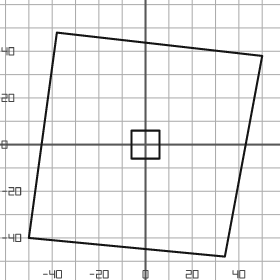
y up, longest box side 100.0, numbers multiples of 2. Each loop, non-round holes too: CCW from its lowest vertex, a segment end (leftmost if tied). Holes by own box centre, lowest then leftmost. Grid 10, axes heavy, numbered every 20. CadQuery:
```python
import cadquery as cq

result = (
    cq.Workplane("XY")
    .moveTo(34.0, -48.0)
    .lineTo(50.0, 38.0)
    .lineTo(-38.0, 48.0)
    .lineTo(-50.0, -40.0)
    .close()
    .moveTo(-6.0, -6.0)
    .lineTo(6.0, -6.0)
    .lineTo(6.0, 6.0)
    .lineTo(-6.0, 6.0)
    .close()
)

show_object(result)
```